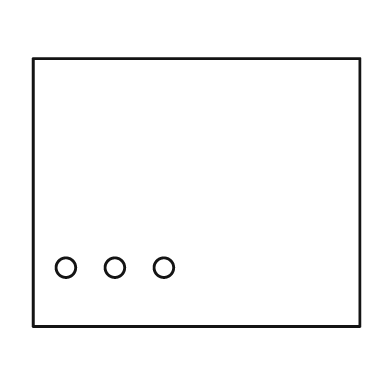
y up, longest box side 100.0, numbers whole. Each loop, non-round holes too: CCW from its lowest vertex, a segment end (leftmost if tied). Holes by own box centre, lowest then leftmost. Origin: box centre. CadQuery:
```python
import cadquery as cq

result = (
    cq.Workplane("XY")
    .moveTo(-50.0, -41.0)
    .lineTo(50.0, -41.0)
    .lineTo(50.0, 41.0)
    .lineTo(-50.0, 41.0)
    .close()
    .moveTo(-40.0, -23.0)
    .circle(3.0)
    .moveTo(-25.0, -23.0)
    .circle(3.0)
    .moveTo(-10.0, -23.0)
    .circle(3.0)
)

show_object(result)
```